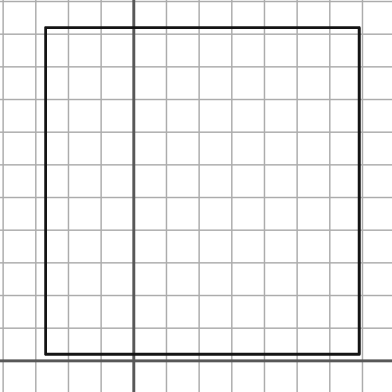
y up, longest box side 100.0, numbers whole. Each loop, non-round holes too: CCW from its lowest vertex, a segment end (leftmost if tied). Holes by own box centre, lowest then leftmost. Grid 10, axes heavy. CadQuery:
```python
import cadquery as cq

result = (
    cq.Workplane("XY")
    .moveTo(-27.0, 2.0)
    .lineTo(69.0, 2.0)
    .lineTo(69.0, 102.0)
    .lineTo(-27.0, 102.0)
    .close()
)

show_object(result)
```